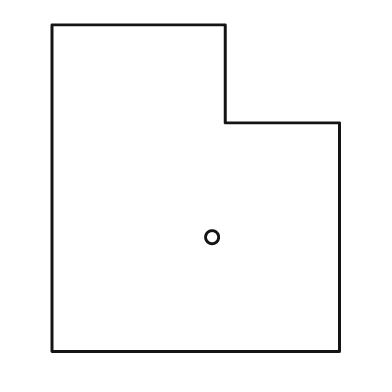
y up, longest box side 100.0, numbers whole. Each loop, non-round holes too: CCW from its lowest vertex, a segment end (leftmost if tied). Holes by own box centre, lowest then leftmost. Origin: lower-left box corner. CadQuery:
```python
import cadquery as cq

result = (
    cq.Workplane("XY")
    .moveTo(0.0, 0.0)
    .lineTo(88.0, 0.0)
    .lineTo(88.0, 70.0)
    .lineTo(53.0, 70.0)
    .lineTo(53.0, 100.0)
    .lineTo(0.0, 100.0)
    .close()
    .moveTo(49.0, 35.0)
    .circle(2.0)
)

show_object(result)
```